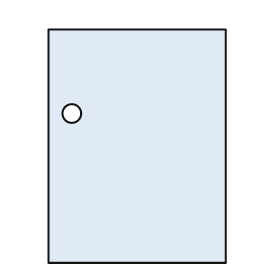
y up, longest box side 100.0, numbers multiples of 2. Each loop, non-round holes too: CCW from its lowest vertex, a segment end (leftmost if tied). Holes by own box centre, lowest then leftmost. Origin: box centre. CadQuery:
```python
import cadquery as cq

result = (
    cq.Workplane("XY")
    .moveTo(-38.0, -50.0)
    .lineTo(38.0, -50.0)
    .lineTo(38.0, 50.0)
    .lineTo(-38.0, 50.0)
    .close()
    .moveTo(-28.0, 14.0)
    .circle(4.0)
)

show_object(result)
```